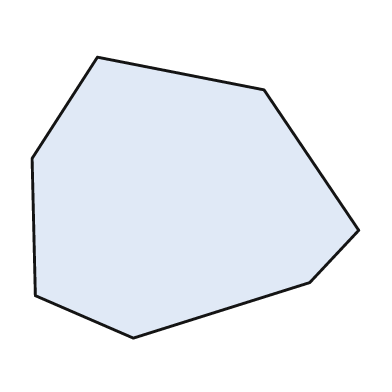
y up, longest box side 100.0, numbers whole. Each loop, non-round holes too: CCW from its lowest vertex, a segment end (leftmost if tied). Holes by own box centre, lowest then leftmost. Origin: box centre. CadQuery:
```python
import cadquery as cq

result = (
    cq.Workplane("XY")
    .moveTo(-19.0, -43.0)
    .lineTo(35.0, -26.0)
    .lineTo(50.0, -10.0)
    .lineTo(21.0, 33.0)
    .lineTo(-30.0, 43.0)
    .lineTo(-50.0, 12.0)
    .lineTo(-49.0, -30.0)
    .close()
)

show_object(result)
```